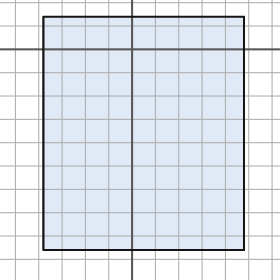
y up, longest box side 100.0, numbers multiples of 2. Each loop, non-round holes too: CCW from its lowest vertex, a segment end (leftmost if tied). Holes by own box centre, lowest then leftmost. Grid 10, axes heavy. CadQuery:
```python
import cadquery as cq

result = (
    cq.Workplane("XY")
    .moveTo(-38.0, -86.0)
    .lineTo(48.0, -86.0)
    .lineTo(48.0, 14.0)
    .lineTo(-38.0, 14.0)
    .close()
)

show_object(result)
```